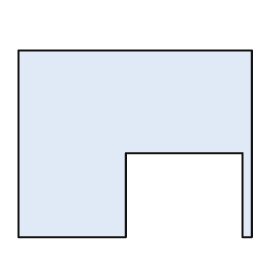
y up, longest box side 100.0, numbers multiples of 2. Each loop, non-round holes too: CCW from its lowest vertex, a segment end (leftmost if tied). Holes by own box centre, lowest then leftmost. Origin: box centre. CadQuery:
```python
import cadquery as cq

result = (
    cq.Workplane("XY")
    .moveTo(-50.0, -40.0)
    .lineTo(-4.0, -40.0)
    .lineTo(-4.0, -4.0)
    .lineTo(46.0, -4.0)
    .lineTo(46.0, -40.0)
    .lineTo(50.0, -40.0)
    .lineTo(50.0, 40.0)
    .lineTo(-50.0, 40.0)
    .close()
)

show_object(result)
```